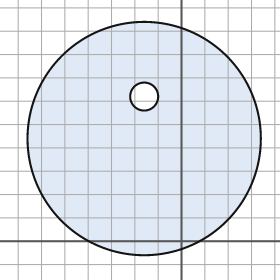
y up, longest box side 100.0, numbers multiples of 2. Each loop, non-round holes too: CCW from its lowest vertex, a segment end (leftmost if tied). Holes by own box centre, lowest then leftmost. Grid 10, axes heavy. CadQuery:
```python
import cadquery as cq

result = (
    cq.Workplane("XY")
    .moveTo(-16.0, 44.0)
    .circle(50.0)
    .moveTo(-16.0, 62.0)
    .circle(6.0)
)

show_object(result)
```